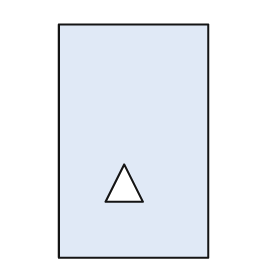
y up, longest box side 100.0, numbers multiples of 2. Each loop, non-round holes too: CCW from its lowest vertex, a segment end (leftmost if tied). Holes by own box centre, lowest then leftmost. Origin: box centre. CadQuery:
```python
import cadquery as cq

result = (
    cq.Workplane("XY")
    .moveTo(-32.0, -50.0)
    .lineTo(32.0, -50.0)
    .lineTo(32.0, 50.0)
    .lineTo(-32.0, 50.0)
    .close()
    .moveTo(-12.0, -26.0)
    .lineTo(4.0, -26.0)
    .lineTo(-4.0, -10.0)
    .close()
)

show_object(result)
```